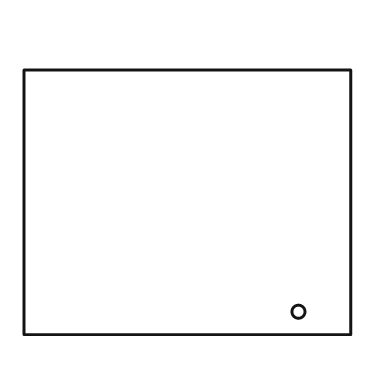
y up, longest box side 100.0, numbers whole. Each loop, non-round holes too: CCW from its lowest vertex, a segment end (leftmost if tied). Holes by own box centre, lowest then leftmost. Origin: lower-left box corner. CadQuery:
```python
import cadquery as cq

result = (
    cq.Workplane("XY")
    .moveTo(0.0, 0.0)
    .lineTo(100.0, 0.0)
    .lineTo(100.0, 81.0)
    .lineTo(0.0, 81.0)
    .close()
    .moveTo(84.0, 7.0)
    .circle(2.0)
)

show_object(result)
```